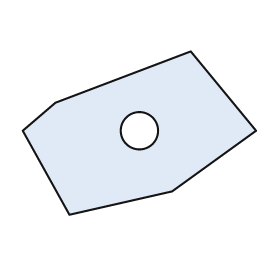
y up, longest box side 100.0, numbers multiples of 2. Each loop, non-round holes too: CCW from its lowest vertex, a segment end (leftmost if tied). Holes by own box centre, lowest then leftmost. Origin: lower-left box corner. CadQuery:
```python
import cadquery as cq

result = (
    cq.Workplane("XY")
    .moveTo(20.0, 0.0)
    .lineTo(64.0, 10.0)
    .lineTo(100.0, 36.0)
    .lineTo(72.0, 70.0)
    .lineTo(14.0, 48.0)
    .lineTo(0.0, 36.0)
    .close()
    .moveTo(50.0, 36.0)
    .circle(8.0)
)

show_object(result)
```